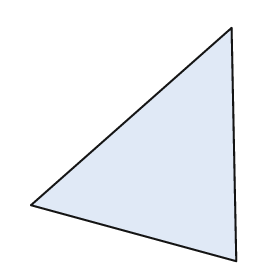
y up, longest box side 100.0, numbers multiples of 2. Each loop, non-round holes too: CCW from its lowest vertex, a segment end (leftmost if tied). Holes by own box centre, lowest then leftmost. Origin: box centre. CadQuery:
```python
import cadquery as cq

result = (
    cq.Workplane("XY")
    .moveTo(44.0, -50.0)
    .lineTo(42.0, 50.0)
    .lineTo(-44.0, -26.0)
    .close()
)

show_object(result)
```